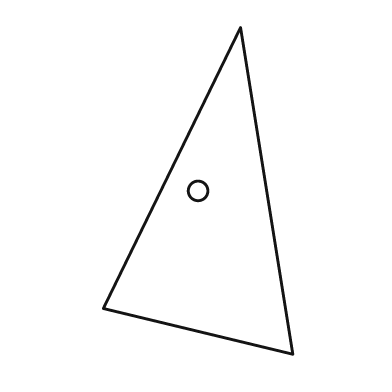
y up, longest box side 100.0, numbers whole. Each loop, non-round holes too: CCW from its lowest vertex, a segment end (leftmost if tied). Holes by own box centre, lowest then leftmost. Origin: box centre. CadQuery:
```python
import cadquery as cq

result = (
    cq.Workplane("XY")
    .moveTo(29.0, -50.0)
    .lineTo(13.0, 50.0)
    .lineTo(-29.0, -36.0)
    .close()
    .moveTo(0.0, 0.0)
    .circle(3.0)
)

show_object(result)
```